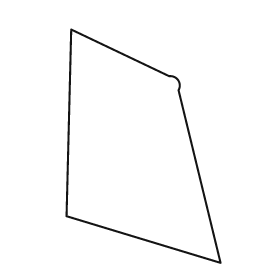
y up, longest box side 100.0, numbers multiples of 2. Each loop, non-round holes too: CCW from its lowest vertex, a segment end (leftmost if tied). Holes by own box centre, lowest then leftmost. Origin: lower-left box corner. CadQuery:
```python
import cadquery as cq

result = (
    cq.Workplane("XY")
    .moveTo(66.0, 0.0)
    .lineTo(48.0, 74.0)
    .threePointArc((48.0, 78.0), (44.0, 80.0))
    .lineTo(2.0, 100.0)
    .lineTo(0.0, 20.0)
    .close()
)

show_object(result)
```